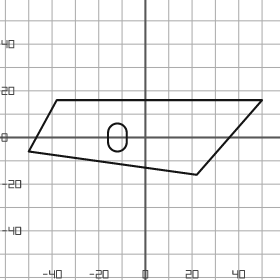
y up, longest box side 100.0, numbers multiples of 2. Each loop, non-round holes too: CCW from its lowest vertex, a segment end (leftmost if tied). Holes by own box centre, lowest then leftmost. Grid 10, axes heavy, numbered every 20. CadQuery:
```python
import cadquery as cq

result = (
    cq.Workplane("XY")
    .moveTo(22.0, -16.0)
    .lineTo(50.0, 16.0)
    .lineTo(-38.0, 16.0)
    .lineTo(-50.0, -6.0)
    .close()
    .moveTo(-16.0, -2.0)
    .threePointArc((-12.0, -6.0), (-8.0, -2.0))
    .lineTo(-8.0, 2.0)
    .threePointArc((-12.0, 6.0), (-16.0, 2.0))
    .close()
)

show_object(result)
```